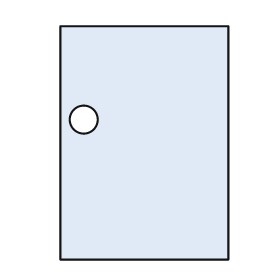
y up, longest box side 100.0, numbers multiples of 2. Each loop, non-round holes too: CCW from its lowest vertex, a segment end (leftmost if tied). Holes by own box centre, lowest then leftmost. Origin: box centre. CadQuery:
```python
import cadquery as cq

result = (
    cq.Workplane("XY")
    .moveTo(-36.0, -50.0)
    .lineTo(36.0, -50.0)
    .lineTo(36.0, 50.0)
    .lineTo(-36.0, 50.0)
    .close()
    .moveTo(-26.0, 10.0)
    .circle(6.0)
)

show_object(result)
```